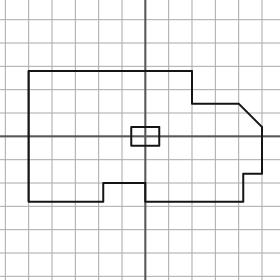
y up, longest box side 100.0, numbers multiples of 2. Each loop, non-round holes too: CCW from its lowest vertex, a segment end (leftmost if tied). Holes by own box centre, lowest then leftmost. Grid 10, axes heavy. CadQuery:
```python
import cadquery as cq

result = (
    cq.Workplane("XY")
    .moveTo(-50.0, -28.0)
    .lineTo(-18.0, -28.0)
    .lineTo(-18.0, -20.0)
    .lineTo(0.0, -20.0)
    .lineTo(0.0, -28.0)
    .lineTo(42.0, -28.0)
    .lineTo(42.0, -16.0)
    .lineTo(50.0, -16.0)
    .lineTo(50.0, 4.0)
    .lineTo(40.0, 14.0)
    .lineTo(20.0, 14.0)
    .lineTo(20.0, 28.0)
    .lineTo(-50.0, 28.0)
    .close()
    .moveTo(-6.0, -4.0)
    .lineTo(6.0, -4.0)
    .lineTo(6.0, 4.0)
    .lineTo(-6.0, 4.0)
    .close()
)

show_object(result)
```